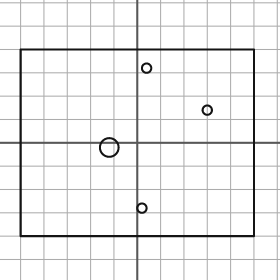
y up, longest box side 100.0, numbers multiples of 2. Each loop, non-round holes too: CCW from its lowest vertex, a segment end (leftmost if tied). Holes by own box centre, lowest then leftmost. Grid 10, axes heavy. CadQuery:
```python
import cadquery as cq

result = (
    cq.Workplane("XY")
    .moveTo(-50.0, -40.0)
    .lineTo(50.0, -40.0)
    .lineTo(50.0, 40.0)
    .lineTo(-50.0, 40.0)
    .close()
    .moveTo(2.0, -28.0)
    .circle(2.0)
    .moveTo(-12.0, -2.0)
    .circle(4.0)
    .moveTo(30.0, 14.0)
    .circle(2.0)
    .moveTo(4.0, 32.0)
    .circle(2.0)
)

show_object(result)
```